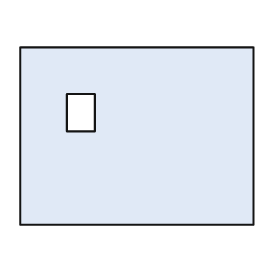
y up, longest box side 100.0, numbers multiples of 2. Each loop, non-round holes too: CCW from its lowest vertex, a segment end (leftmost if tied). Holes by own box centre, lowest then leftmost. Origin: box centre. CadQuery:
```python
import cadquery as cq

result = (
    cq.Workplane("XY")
    .moveTo(-50.0, -38.0)
    .lineTo(50.0, -38.0)
    .lineTo(50.0, 38.0)
    .lineTo(-50.0, 38.0)
    .close()
    .moveTo(-30.0, 2.0)
    .lineTo(-18.0, 2.0)
    .lineTo(-18.0, 18.0)
    .lineTo(-30.0, 18.0)
    .close()
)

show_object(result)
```